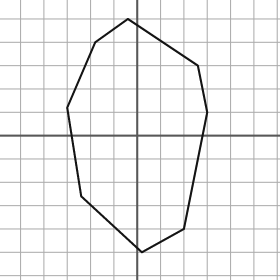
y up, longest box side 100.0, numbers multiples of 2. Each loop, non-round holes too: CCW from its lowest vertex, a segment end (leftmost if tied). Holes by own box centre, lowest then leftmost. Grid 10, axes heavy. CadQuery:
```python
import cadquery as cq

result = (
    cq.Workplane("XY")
    .moveTo(2.0, -50.0)
    .lineTo(20.0, -40.0)
    .lineTo(30.0, 10.0)
    .lineTo(26.0, 30.0)
    .lineTo(-4.0, 50.0)
    .lineTo(-18.0, 40.0)
    .lineTo(-30.0, 12.0)
    .lineTo(-24.0, -26.0)
    .close()
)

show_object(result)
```